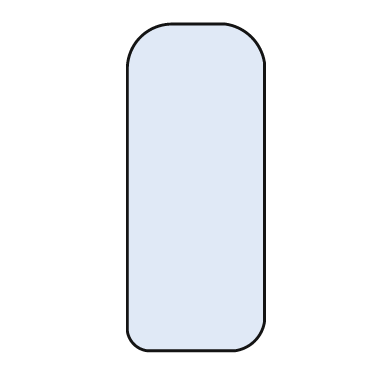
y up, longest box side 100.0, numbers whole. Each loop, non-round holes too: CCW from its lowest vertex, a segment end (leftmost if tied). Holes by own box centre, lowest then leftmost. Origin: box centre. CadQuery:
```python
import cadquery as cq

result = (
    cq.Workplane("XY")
    .moveTo(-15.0, -50.0)
    .lineTo(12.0, -50.0)
    .threePointArc((18.0, -47.0), (21.0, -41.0))
    .lineTo(21.0, 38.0)
    .threePointArc((17.0, 46.0), (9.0, 50.0))
    .lineTo(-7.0, 50.0)
    .threePointArc((-17.0, 46.0), (-21.0, 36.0))
    .lineTo(-21.0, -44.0)
    .threePointArc((-19.0, -48.0), (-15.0, -50.0))
    .close()
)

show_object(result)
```